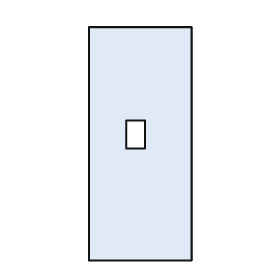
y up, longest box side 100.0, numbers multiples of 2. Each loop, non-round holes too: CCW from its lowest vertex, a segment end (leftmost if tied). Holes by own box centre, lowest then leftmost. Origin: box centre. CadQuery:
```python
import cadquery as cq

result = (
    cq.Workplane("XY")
    .moveTo(-22.0, -50.0)
    .lineTo(22.0, -50.0)
    .lineTo(22.0, 50.0)
    .lineTo(-22.0, 50.0)
    .close()
    .moveTo(-6.0, -2.0)
    .lineTo(2.0, -2.0)
    .lineTo(2.0, 10.0)
    .lineTo(-6.0, 10.0)
    .close()
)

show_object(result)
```